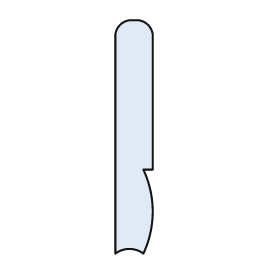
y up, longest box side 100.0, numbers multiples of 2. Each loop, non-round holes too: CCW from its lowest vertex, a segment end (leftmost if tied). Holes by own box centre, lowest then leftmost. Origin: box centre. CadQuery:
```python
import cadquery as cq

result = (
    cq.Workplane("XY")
    .moveTo(-8.0, -50.0)
    .threePointArc((-2.0, -48.0), (4.0, -50.0))
    .threePointArc((8.0, -32.0), (4.0, -14.0))
    .lineTo(8.0, -14.0)
    .lineTo(8.0, 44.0)
    .threePointArc((6.0, 48.0), (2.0, 50.0))
    .lineTo(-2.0, 50.0)
    .threePointArc((-6.0, 48.0), (-8.0, 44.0))
    .close()
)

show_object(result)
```